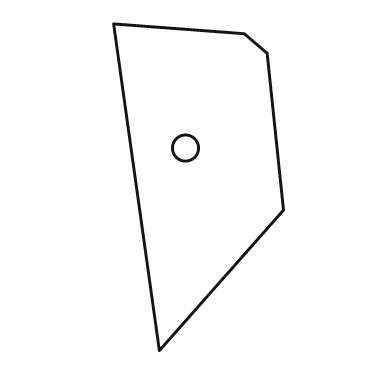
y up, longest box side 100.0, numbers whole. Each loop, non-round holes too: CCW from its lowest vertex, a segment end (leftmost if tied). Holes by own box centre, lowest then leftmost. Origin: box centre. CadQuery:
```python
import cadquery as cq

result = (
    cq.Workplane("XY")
    .moveTo(-12.0, -50.0)
    .lineTo(26.0, -7.0)
    .lineTo(21.0, 41.0)
    .lineTo(14.0, 47.0)
    .lineTo(-26.0, 50.0)
    .close()
    .moveTo(-4.0, 12.0)
    .circle(4.0)
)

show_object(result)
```